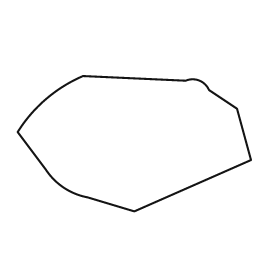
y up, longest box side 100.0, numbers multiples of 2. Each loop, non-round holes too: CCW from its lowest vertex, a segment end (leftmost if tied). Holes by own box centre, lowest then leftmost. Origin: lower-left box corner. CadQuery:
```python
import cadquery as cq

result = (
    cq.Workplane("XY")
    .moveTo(50.0, 0.0)
    .lineTo(100.0, 22.0)
    .lineTo(94.0, 44.0)
    .lineTo(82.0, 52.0)
    .threePointArc((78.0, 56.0), (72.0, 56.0))
    .lineTo(28.0, 58.0)
    .threePointArc((12.0, 48.0), (0.0, 34.0))
    .lineTo(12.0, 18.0)
    .threePointArc((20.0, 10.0), (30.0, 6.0))
    .close()
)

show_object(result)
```